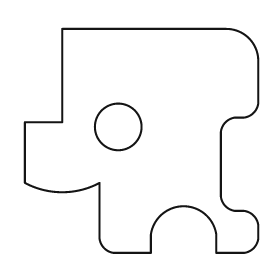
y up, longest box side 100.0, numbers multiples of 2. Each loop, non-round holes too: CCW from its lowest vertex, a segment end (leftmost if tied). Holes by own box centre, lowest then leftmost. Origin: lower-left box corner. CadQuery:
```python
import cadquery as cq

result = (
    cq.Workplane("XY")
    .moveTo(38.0, 0.0)
    .lineTo(54.0, 0.0)
    .lineTo(54.0, 8.0)
    .threePointArc((68.0, 20.0), (82.0, 8.0))
    .lineTo(82.0, 0.0)
    .lineTo(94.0, 0.0)
    .threePointArc((98.0, 2.0), (100.0, 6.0))
    .lineTo(100.0, 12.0)
    .threePointArc((98.0, 16.0), (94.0, 18.0))
    .lineTo(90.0, 18.0)
    .threePointArc((86.0, 20.0), (84.0, 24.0))
    .lineTo(84.0, 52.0)
    .threePointArc((86.0, 56.0), (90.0, 58.0))
    .lineTo(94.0, 58.0)
    .threePointArc((98.0, 60.0), (100.0, 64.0))
    .lineTo(100.0, 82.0)
    .threePointArc((96.0, 92.0), (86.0, 96.0))
    .lineTo(16.0, 96.0)
    .lineTo(16.0, 56.0)
    .lineTo(0.0, 56.0)
    .lineTo(0.0, 30.0)
    .threePointArc((16.0, 26.0), (32.0, 30.0))
    .lineTo(32.0, 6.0)
    .threePointArc((34.0, 2.0), (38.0, 0.0))
    .close()
    .moveTo(40.0, 54.0)
    .circle(10.0)
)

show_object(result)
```